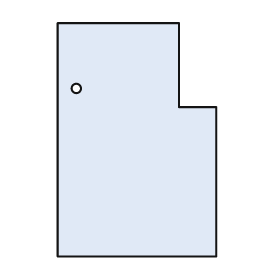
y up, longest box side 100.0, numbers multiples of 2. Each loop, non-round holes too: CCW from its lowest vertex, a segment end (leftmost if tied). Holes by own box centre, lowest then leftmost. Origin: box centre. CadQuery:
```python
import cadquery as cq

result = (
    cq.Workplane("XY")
    .moveTo(-34.0, -50.0)
    .lineTo(34.0, -50.0)
    .lineTo(34.0, 14.0)
    .lineTo(18.0, 14.0)
    .lineTo(18.0, 50.0)
    .lineTo(-34.0, 50.0)
    .close()
    .moveTo(-26.0, 22.0)
    .circle(2.0)
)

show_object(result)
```